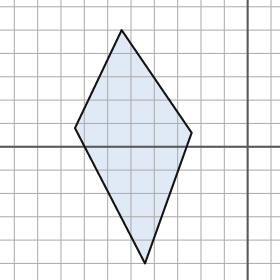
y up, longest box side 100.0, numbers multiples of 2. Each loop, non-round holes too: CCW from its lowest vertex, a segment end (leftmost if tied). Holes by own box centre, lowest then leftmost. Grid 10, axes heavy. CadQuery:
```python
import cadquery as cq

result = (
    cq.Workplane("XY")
    .moveTo(-44.0, -50.0)
    .lineTo(-24.0, 6.0)
    .lineTo(-54.0, 50.0)
    .lineTo(-74.0, 8.0)
    .close()
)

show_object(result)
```